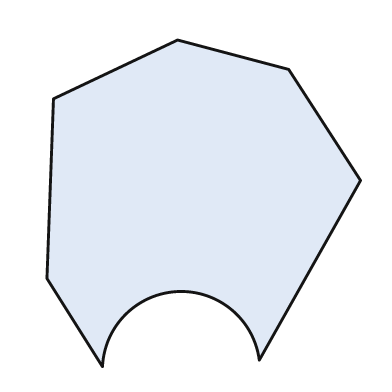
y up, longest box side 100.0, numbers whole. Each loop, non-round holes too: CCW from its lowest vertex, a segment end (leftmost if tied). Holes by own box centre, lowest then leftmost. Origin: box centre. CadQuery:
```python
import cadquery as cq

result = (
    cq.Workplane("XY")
    .moveTo(-31.0, -50.0)
    .threePointArc((-8.0, -27.0), (17.0, -48.0))
    .lineTo(48.0, 7.0)
    .lineTo(26.0, 41.0)
    .lineTo(-8.0, 50.0)
    .lineTo(-46.0, 32.0)
    .lineTo(-48.0, -23.0)
    .close()
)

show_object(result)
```